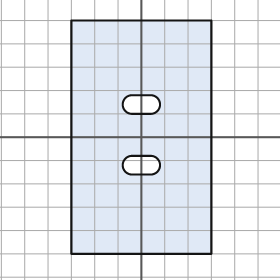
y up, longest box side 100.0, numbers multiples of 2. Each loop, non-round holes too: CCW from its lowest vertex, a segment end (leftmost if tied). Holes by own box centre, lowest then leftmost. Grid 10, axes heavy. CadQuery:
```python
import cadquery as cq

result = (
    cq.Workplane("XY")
    .moveTo(-30.0, -50.0)
    .lineTo(30.0, -50.0)
    .lineTo(30.0, 50.0)
    .lineTo(-30.0, 50.0)
    .close()
    .moveTo(-4.0, -16.0)
    .lineTo(4.0, -16.0)
    .threePointArc((8.0, -12.0), (4.0, -8.0))
    .lineTo(-4.0, -8.0)
    .threePointArc((-8.0, -12.0), (-4.0, -16.0))
    .close()
    .moveTo(-4.0, 10.0)
    .lineTo(4.0, 10.0)
    .threePointArc((8.0, 14.0), (4.0, 18.0))
    .lineTo(-4.0, 18.0)
    .threePointArc((-8.0, 14.0), (-4.0, 10.0))
    .close()
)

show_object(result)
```